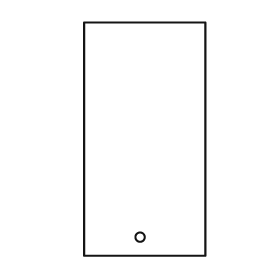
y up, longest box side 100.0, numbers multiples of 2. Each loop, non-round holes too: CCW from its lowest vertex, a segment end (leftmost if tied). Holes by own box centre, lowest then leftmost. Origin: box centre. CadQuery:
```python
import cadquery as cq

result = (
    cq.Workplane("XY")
    .moveTo(-26.0, -50.0)
    .lineTo(26.0, -50.0)
    .lineTo(26.0, 50.0)
    .lineTo(-26.0, 50.0)
    .close()
    .moveTo(-2.0, -42.0)
    .circle(2.0)
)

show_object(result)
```